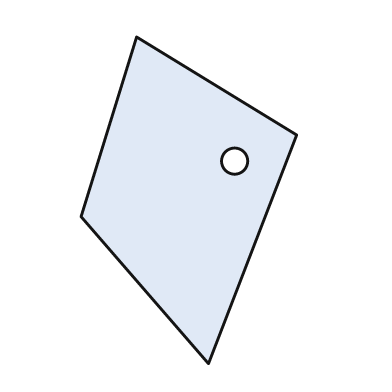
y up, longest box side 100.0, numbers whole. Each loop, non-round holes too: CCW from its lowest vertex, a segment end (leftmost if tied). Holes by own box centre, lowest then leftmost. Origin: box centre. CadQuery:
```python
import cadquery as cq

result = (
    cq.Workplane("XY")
    .moveTo(6.0, -50.0)
    .lineTo(33.0, 20.0)
    .lineTo(-16.0, 50.0)
    .lineTo(-33.0, -5.0)
    .close()
    .moveTo(14.0, 12.0)
    .circle(4.0)
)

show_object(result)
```